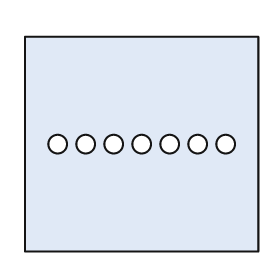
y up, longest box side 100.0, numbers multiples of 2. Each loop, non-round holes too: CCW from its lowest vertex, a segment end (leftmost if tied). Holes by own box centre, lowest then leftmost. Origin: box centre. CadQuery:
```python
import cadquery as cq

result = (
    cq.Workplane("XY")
    .moveTo(-50.0, -46.0)
    .lineTo(50.0, -46.0)
    .lineTo(50.0, 46.0)
    .lineTo(-50.0, 46.0)
    .close()
    .moveTo(-36.0, 0.0)
    .circle(4.0)
    .moveTo(-24.0, 0.0)
    .circle(4.0)
    .moveTo(-12.0, 0.0)
    .circle(4.0)
    .moveTo(0.0, 0.0)
    .circle(4.0)
    .moveTo(12.0, 0.0)
    .circle(4.0)
    .moveTo(24.0, 0.0)
    .circle(4.0)
    .moveTo(36.0, 0.0)
    .circle(4.0)
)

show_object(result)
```